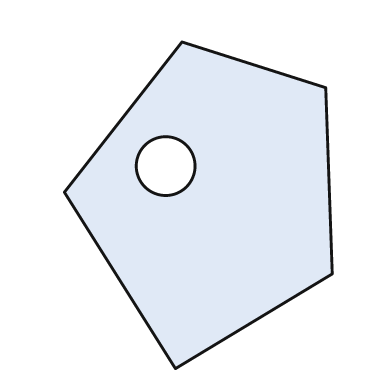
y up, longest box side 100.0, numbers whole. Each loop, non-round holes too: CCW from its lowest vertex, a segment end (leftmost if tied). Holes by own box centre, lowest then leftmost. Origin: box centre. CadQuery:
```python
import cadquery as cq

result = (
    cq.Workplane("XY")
    .moveTo(-7.0, -50.0)
    .lineTo(41.0, -21.0)
    .lineTo(39.0, 36.0)
    .lineTo(-5.0, 50.0)
    .lineTo(-41.0, 4.0)
    .close()
    .moveTo(-10.0, 12.0)
    .circle(9.0)
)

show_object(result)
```